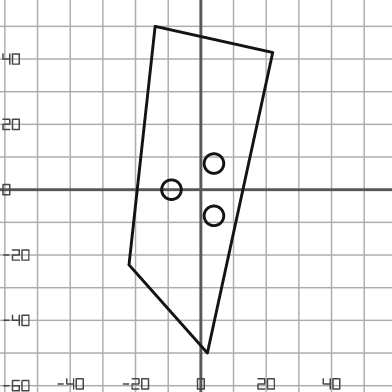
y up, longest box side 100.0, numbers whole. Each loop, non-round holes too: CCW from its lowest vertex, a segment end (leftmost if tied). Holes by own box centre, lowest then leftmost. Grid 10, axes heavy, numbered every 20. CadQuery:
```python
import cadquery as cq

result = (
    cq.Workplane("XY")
    .moveTo(2.0, -50.0)
    .lineTo(22.0, 42.0)
    .lineTo(-14.0, 50.0)
    .lineTo(-22.0, -23.0)
    .close()
    .moveTo(4.0, -8.0)
    .circle(3.0)
    .moveTo(-9.0, 0.0)
    .circle(3.0)
    .moveTo(4.0, 8.0)
    .circle(3.0)
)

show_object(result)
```